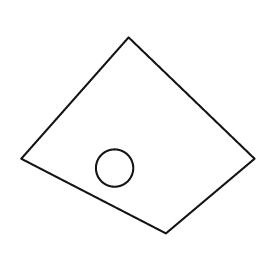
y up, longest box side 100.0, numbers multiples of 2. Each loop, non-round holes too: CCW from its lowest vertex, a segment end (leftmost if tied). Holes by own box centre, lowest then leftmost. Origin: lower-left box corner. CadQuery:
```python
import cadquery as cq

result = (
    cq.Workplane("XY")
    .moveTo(62.0, 0.0)
    .lineTo(100.0, 32.0)
    .lineTo(46.0, 84.0)
    .lineTo(0.0, 32.0)
    .close()
    .moveTo(40.0, 28.0)
    .circle(8.0)
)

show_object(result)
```